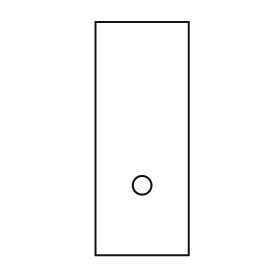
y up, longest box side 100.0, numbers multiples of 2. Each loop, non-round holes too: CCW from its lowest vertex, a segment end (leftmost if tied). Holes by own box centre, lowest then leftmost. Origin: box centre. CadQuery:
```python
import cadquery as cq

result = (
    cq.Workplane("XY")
    .moveTo(-20.0, -50.0)
    .lineTo(20.0, -50.0)
    .lineTo(20.0, 50.0)
    .lineTo(-20.0, 50.0)
    .close()
    .moveTo(0.0, -20.0)
    .circle(4.0)
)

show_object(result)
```